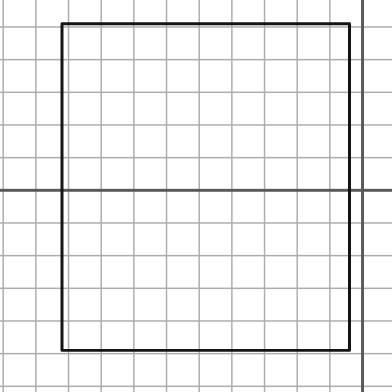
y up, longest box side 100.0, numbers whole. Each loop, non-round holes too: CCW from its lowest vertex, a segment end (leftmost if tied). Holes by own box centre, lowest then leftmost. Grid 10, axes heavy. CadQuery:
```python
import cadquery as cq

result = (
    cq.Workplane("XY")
    .moveTo(-92.0, -49.0)
    .lineTo(-4.0, -49.0)
    .lineTo(-4.0, 51.0)
    .lineTo(-92.0, 51.0)
    .close()
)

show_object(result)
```